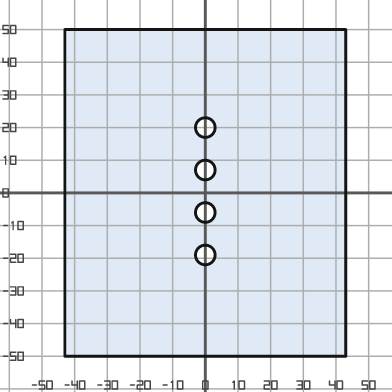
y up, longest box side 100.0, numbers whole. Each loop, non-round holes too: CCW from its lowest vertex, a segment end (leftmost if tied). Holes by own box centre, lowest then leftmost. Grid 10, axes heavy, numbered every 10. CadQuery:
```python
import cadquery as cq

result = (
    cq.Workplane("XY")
    .moveTo(-43.0, -50.0)
    .lineTo(43.0, -50.0)
    .lineTo(43.0, 50.0)
    .lineTo(-43.0, 50.0)
    .close()
    .moveTo(0.0, -19.0)
    .circle(3.0)
    .moveTo(0.0, -6.0)
    .circle(3.0)
    .moveTo(0.0, 7.0)
    .circle(3.0)
    .moveTo(0.0, 20.0)
    .circle(3.0)
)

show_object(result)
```